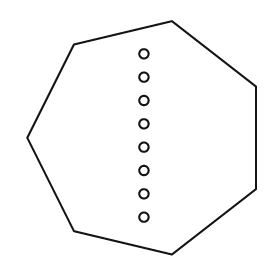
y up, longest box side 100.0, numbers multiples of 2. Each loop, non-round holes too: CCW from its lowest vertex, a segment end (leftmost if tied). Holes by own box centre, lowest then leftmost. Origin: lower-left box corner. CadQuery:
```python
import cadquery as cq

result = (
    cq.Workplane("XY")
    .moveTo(62.0, 0.0)
    .lineTo(98.0, 28.0)
    .lineTo(98.0, 72.0)
    .lineTo(62.0, 100.0)
    .lineTo(20.0, 90.0)
    .lineTo(0.0, 50.0)
    .lineTo(20.0, 10.0)
    .close()
    .moveTo(50.0, 16.0)
    .circle(2.0)
    .moveTo(50.0, 26.0)
    .circle(2.0)
    .moveTo(50.0, 36.0)
    .circle(2.0)
    .moveTo(50.0, 46.0)
    .circle(2.0)
    .moveTo(50.0, 56.0)
    .circle(2.0)
    .moveTo(50.0, 66.0)
    .circle(2.0)
    .moveTo(50.0, 76.0)
    .circle(2.0)
    .moveTo(50.0, 86.0)
    .circle(2.0)
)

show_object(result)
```